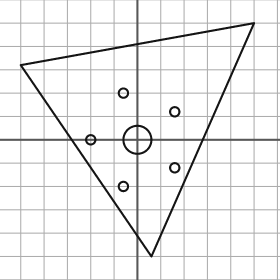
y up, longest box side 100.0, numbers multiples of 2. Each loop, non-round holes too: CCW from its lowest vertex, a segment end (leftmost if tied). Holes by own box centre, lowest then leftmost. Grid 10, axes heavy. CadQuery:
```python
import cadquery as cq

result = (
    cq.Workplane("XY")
    .moveTo(6.0, -50.0)
    .lineTo(50.0, 50.0)
    .lineTo(-50.0, 32.0)
    .close()
    .moveTo(-6.0, -20.0)
    .circle(2.0)
    .moveTo(16.0, -12.0)
    .circle(2.0)
    .moveTo(-20.0, 0.0)
    .circle(2.0)
    .moveTo(0.0, 0.0)
    .circle(6.0)
    .moveTo(16.0, 12.0)
    .circle(2.0)
    .moveTo(-6.0, 20.0)
    .circle(2.0)
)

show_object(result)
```